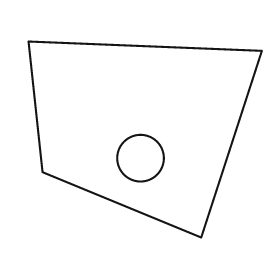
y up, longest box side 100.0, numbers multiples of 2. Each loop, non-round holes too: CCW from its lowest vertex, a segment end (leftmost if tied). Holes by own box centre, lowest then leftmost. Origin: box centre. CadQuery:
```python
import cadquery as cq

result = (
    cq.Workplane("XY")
    .moveTo(24.0, -42.0)
    .lineTo(50.0, 38.0)
    .lineTo(-50.0, 42.0)
    .lineTo(-44.0, -14.0)
    .close()
    .moveTo(-2.0, -8.0)
    .circle(10.0)
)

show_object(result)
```